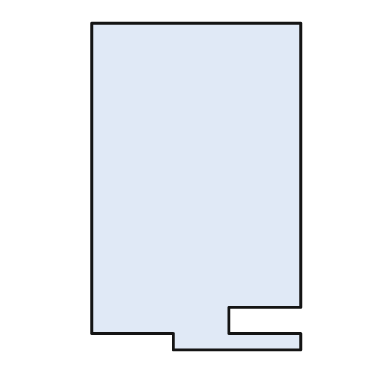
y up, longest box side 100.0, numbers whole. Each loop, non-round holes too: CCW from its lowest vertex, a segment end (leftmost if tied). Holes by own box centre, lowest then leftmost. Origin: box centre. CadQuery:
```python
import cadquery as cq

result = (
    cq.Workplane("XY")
    .moveTo(-7.0, -50.0)
    .lineTo(32.0, -50.0)
    .lineTo(32.0, -45.0)
    .lineTo(10.0, -45.0)
    .lineTo(10.0, -37.0)
    .lineTo(32.0, -37.0)
    .lineTo(32.0, 50.0)
    .lineTo(-32.0, 50.0)
    .lineTo(-32.0, -45.0)
    .lineTo(-7.0, -45.0)
    .close()
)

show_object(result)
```